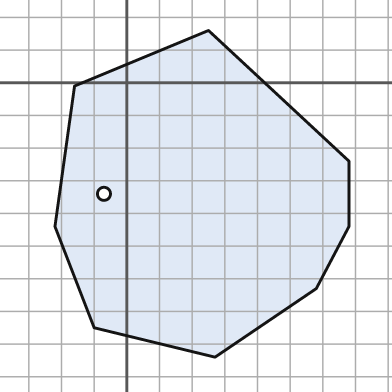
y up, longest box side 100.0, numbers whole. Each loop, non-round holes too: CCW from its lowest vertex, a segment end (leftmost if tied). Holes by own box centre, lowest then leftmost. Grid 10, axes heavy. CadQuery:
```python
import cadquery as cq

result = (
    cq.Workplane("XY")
    .moveTo(27.0, -84.0)
    .lineTo(58.0, -63.0)
    .lineTo(68.0, -44.0)
    .lineTo(68.0, -24.0)
    .lineTo(25.0, 16.0)
    .lineTo(-16.0, -1.0)
    .lineTo(-22.0, -44.0)
    .lineTo(-10.0, -75.0)
    .close()
    .moveTo(-7.0, -34.0)
    .circle(2.0)
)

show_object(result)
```